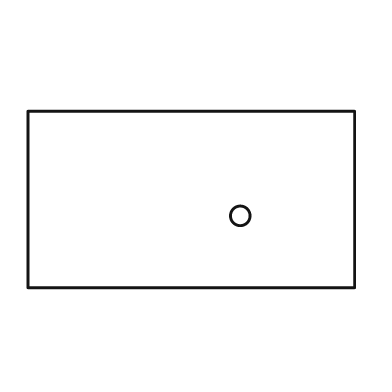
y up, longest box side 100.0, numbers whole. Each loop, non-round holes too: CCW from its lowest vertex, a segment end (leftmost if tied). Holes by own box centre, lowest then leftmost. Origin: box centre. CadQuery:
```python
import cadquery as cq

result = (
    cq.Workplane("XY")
    .moveTo(-50.0, -27.0)
    .lineTo(50.0, -27.0)
    .lineTo(50.0, 27.0)
    .lineTo(-50.0, 27.0)
    .close()
    .moveTo(15.0, -5.0)
    .circle(3.0)
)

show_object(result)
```